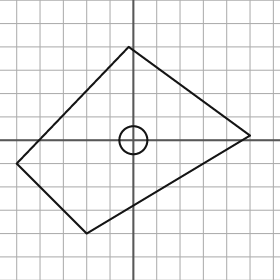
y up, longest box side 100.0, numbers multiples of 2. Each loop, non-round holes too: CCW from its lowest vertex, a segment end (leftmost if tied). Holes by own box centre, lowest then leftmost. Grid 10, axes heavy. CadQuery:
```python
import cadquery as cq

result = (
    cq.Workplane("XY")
    .moveTo(-20.0, -40.0)
    .lineTo(50.0, 2.0)
    .lineTo(-2.0, 40.0)
    .lineTo(-50.0, -10.0)
    .close()
    .moveTo(0.0, 0.0)
    .circle(6.0)
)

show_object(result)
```